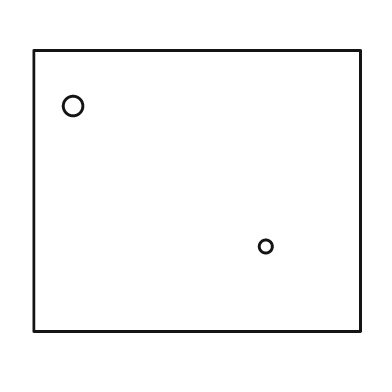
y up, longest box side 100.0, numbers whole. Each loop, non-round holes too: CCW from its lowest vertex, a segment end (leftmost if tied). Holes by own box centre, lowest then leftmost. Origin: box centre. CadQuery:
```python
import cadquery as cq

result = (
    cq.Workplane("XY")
    .moveTo(-50.0, -43.0)
    .lineTo(50.0, -43.0)
    .lineTo(50.0, 43.0)
    .lineTo(-50.0, 43.0)
    .close()
    .moveTo(21.0, -17.0)
    .circle(2.0)
    .moveTo(-38.0, 26.0)
    .circle(3.0)
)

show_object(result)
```